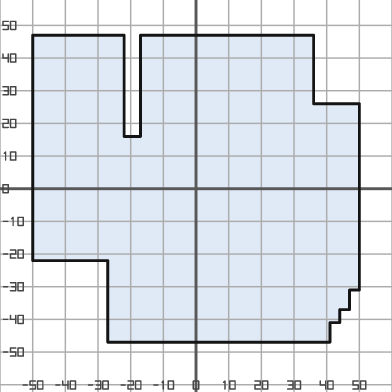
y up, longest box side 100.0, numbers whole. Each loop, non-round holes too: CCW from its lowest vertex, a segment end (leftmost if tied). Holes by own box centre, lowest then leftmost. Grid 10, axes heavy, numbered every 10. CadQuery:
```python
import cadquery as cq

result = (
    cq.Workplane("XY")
    .moveTo(-27.0, -47.0)
    .lineTo(41.0, -47.0)
    .lineTo(41.0, -41.0)
    .lineTo(44.0, -41.0)
    .lineTo(44.0, -37.0)
    .lineTo(47.0, -37.0)
    .lineTo(47.0, -31.0)
    .lineTo(50.0, -31.0)
    .lineTo(50.0, 26.0)
    .lineTo(36.0, 26.0)
    .lineTo(36.0, 47.0)
    .lineTo(-17.0, 47.0)
    .lineTo(-17.0, 16.0)
    .lineTo(-22.0, 16.0)
    .lineTo(-22.0, 47.0)
    .lineTo(-50.0, 47.0)
    .lineTo(-50.0, -22.0)
    .lineTo(-27.0, -22.0)
    .close()
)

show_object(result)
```